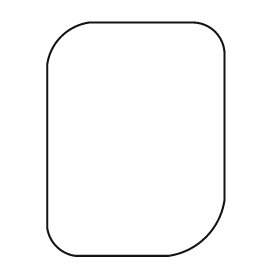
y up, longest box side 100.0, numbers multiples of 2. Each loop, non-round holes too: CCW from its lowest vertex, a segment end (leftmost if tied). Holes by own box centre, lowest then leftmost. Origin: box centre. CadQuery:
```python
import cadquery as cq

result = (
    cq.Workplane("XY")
    .moveTo(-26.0, -50.0)
    .lineTo(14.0, -50.0)
    .threePointArc((30.0, -42.0), (38.0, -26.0))
    .lineTo(38.0, 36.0)
    .threePointArc((34.0, 46.0), (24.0, 50.0))
    .lineTo(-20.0, 50.0)
    .threePointArc((-32.0, 44.0), (-38.0, 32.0))
    .lineTo(-38.0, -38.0)
    .threePointArc((-34.0, -46.0), (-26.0, -50.0))
    .close()
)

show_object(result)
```